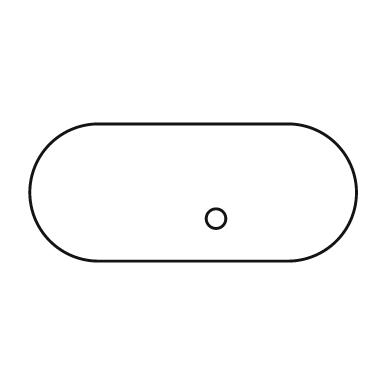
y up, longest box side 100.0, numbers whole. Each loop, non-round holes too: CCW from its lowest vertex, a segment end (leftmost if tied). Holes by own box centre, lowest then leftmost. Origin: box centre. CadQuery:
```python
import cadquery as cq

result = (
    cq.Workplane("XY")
    .moveTo(-29.0, -21.0)
    .lineTo(29.0, -21.0)
    .threePointArc((50.0, 0.0), (29.0, 21.0))
    .lineTo(-29.0, 21.0)
    .threePointArc((-50.0, 0.0), (-29.0, -21.0))
    .close()
    .moveTo(7.0, -8.0)
    .circle(3.0)
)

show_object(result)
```